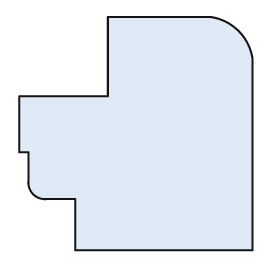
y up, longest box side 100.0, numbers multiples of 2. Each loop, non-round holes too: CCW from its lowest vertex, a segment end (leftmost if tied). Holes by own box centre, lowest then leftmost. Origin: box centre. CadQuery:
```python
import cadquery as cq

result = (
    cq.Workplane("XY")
    .moveTo(-26.0, -50.0)
    .lineTo(50.0, -50.0)
    .lineTo(50.0, 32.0)
    .threePointArc((44.0, 44.0), (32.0, 50.0))
    .lineTo(-12.0, 50.0)
    .lineTo(-12.0, 16.0)
    .lineTo(-50.0, 16.0)
    .lineTo(-50.0, -8.0)
    .lineTo(-46.0, -8.0)
    .lineTo(-46.0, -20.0)
    .threePointArc((-44.0, -26.0), (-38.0, -28.0))
    .lineTo(-26.0, -28.0)
    .close()
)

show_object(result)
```